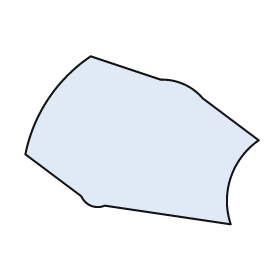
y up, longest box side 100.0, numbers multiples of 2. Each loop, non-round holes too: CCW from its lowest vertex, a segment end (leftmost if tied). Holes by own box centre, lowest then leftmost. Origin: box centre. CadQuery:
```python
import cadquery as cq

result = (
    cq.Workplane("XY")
    .moveTo(38.0, -36.0)
    .threePointArc((38.0, -16.0), (50.0, 0.0))
    .lineTo(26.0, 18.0)
    .threePointArc((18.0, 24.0), (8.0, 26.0))
    .lineTo(-22.0, 36.0)
    .threePointArc((-40.0, 18.0), (-50.0, -6.0))
    .lineTo(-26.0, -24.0)
    .threePointArc((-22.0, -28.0), (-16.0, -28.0))
    .close()
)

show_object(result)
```